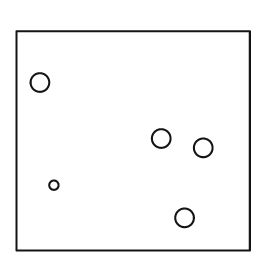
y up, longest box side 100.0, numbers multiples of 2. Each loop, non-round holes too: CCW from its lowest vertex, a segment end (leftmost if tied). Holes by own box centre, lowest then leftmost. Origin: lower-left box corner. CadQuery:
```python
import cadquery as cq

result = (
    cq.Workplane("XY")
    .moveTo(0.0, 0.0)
    .lineTo(100.0, 0.0)
    .lineTo(100.0, 94.0)
    .lineTo(0.0, 94.0)
    .close()
    .moveTo(72.0, 14.0)
    .circle(4.0)
    .moveTo(16.0, 28.0)
    .circle(2.0)
    .moveTo(80.0, 44.0)
    .circle(4.0)
    .moveTo(62.0, 48.0)
    .circle(4.0)
    .moveTo(10.0, 72.0)
    .circle(4.0)
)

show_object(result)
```